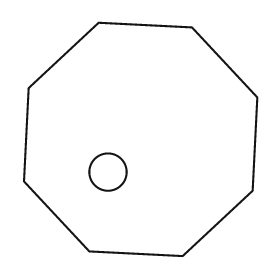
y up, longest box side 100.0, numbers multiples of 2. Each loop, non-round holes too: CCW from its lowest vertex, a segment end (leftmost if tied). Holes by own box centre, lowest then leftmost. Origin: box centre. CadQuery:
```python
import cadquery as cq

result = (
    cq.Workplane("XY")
    .moveTo(18.0, -50.0)
    .lineTo(48.0, -22.0)
    .lineTo(50.0, 18.0)
    .lineTo(22.0, 48.0)
    .lineTo(-18.0, 50.0)
    .lineTo(-48.0, 22.0)
    .lineTo(-50.0, -18.0)
    .lineTo(-22.0, -48.0)
    .close()
    .moveTo(-14.0, -14.0)
    .circle(8.0)
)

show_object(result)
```